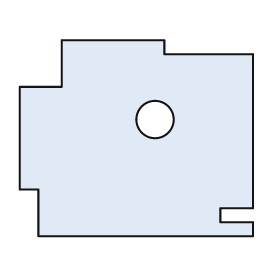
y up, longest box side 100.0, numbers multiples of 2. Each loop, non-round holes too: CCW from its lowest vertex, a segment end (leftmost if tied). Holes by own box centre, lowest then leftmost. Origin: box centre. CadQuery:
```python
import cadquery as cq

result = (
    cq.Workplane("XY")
    .moveTo(-42.0, -42.0)
    .lineTo(50.0, -42.0)
    .lineTo(50.0, -36.0)
    .lineTo(36.0, -36.0)
    .lineTo(36.0, -30.0)
    .lineTo(50.0, -30.0)
    .lineTo(50.0, 36.0)
    .lineTo(12.0, 36.0)
    .lineTo(12.0, 42.0)
    .lineTo(-32.0, 42.0)
    .lineTo(-32.0, 22.0)
    .lineTo(-50.0, 22.0)
    .lineTo(-50.0, -22.0)
    .lineTo(-42.0, -22.0)
    .close()
    .moveTo(8.0, 8.0)
    .circle(8.0)
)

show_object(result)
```